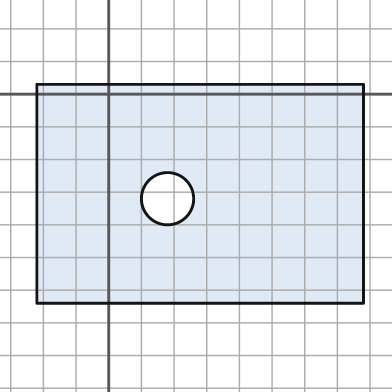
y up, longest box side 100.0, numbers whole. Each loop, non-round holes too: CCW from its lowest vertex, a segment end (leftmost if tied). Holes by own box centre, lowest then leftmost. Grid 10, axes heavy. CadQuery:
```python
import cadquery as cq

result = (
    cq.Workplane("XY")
    .moveTo(-22.0, -64.0)
    .lineTo(78.0, -64.0)
    .lineTo(78.0, 3.0)
    .lineTo(-22.0, 3.0)
    .close()
    .moveTo(18.0, -32.0)
    .circle(8.0)
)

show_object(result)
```